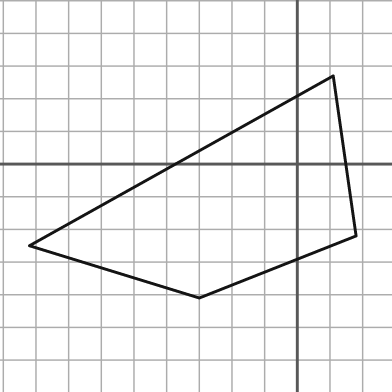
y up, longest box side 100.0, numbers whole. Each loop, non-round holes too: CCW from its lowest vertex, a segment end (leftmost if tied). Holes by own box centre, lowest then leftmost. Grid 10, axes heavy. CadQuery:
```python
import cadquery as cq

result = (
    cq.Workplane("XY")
    .moveTo(-30.0, -41.0)
    .lineTo(18.0, -22.0)
    .lineTo(11.0, 27.0)
    .lineTo(-82.0, -25.0)
    .close()
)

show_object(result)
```